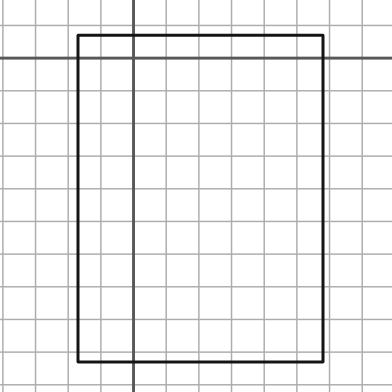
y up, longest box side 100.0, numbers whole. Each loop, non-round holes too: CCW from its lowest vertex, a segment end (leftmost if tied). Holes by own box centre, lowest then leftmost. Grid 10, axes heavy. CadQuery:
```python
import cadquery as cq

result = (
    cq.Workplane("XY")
    .moveTo(-17.0, -93.0)
    .lineTo(58.0, -93.0)
    .lineTo(58.0, 7.0)
    .lineTo(-17.0, 7.0)
    .close()
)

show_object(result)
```